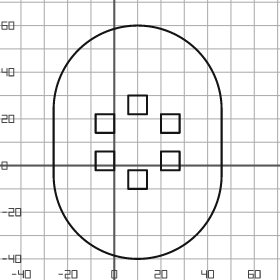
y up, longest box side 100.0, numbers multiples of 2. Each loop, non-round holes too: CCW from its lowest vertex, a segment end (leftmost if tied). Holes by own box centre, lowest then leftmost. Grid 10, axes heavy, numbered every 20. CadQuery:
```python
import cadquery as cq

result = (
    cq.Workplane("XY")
    .moveTo(-26.0, -4.0)
    .threePointArc((10.0, -40.0), (46.0, -4.0))
    .lineTo(46.0, 24.0)
    .threePointArc((10.0, 60.0), (-26.0, 24.0))
    .close()
    .moveTo(6.0, -10.0)
    .lineTo(14.0, -10.0)
    .lineTo(14.0, -2.0)
    .lineTo(6.0, -2.0)
    .close()
    .moveTo(-8.0, -2.0)
    .lineTo(0.0, -2.0)
    .lineTo(0.0, 6.0)
    .lineTo(-8.0, 6.0)
    .close()
    .moveTo(20.0, -2.0)
    .lineTo(28.0, -2.0)
    .lineTo(28.0, 6.0)
    .lineTo(20.0, 6.0)
    .close()
    .moveTo(-8.0, 14.0)
    .lineTo(0.0, 14.0)
    .lineTo(0.0, 22.0)
    .lineTo(-8.0, 22.0)
    .close()
    .moveTo(20.0, 14.0)
    .lineTo(28.0, 14.0)
    .lineTo(28.0, 22.0)
    .lineTo(20.0, 22.0)
    .close()
    .moveTo(6.0, 22.0)
    .lineTo(14.0, 22.0)
    .lineTo(14.0, 30.0)
    .lineTo(6.0, 30.0)
    .close()
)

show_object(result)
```